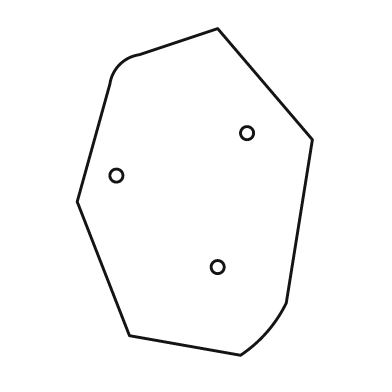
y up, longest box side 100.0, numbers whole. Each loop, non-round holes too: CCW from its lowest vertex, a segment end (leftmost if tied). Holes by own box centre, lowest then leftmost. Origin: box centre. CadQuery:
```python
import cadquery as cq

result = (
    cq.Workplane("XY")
    .moveTo(14.0, -50.0)
    .threePointArc((22.0, -43.0), (28.0, -34.0))
    .lineTo(36.0, 16.0)
    .lineTo(7.0, 50.0)
    .lineTo(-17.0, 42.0)
    .threePointArc((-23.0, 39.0), (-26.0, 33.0))
    .lineTo(-36.0, -3.0)
    .lineTo(-20.0, -44.0)
    .close()
    .moveTo(7.0, -23.0)
    .circle(2.0)
    .moveTo(-24.0, 5.0)
    .circle(2.0)
    .moveTo(16.0, 18.0)
    .circle(2.0)
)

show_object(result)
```